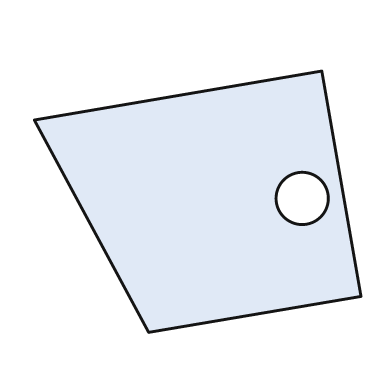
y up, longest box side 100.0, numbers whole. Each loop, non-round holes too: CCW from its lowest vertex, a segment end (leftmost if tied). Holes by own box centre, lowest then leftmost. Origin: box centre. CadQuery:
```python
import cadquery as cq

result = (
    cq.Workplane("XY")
    .moveTo(-15.0, -40.0)
    .lineTo(50.0, -29.0)
    .lineTo(38.0, 40.0)
    .lineTo(-50.0, 25.0)
    .close()
    .moveTo(32.0, 1.0)
    .circle(8.0)
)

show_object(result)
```